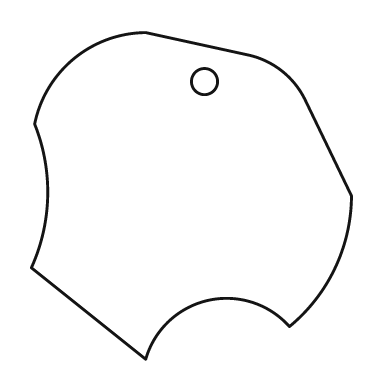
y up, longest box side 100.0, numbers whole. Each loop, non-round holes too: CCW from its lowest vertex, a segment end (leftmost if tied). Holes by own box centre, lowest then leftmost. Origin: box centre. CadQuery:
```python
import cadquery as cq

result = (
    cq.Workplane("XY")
    .moveTo(-14.0, -50.0)
    .threePointArc((5.0, -32.0), (30.0, -40.0))
    .threePointArc((44.0, -22.0), (49.0, 0.0))
    .lineTo(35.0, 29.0)
    .threePointArc((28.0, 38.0), (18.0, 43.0))
    .lineTo(-14.0, 50.0)
    .threePointArc((-36.0, 42.0), (-48.0, 22.0))
    .threePointArc((-44.0, 0.0), (-49.0, -22.0))
    .close()
    .moveTo(4.0, 35.0)
    .circle(4.0)
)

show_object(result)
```